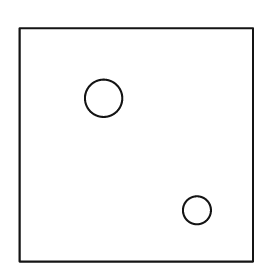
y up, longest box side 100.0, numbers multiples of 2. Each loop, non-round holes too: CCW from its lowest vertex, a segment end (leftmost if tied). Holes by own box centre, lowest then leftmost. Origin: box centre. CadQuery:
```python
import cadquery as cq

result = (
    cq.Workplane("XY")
    .moveTo(-50.0, -50.0)
    .lineTo(50.0, -50.0)
    .lineTo(50.0, 50.0)
    .lineTo(-50.0, 50.0)
    .close()
    .moveTo(26.0, -28.0)
    .circle(6.0)
    .moveTo(-14.0, 20.0)
    .circle(8.0)
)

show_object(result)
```